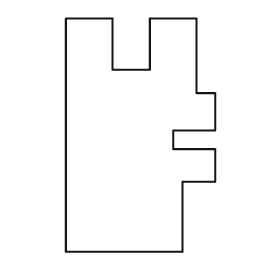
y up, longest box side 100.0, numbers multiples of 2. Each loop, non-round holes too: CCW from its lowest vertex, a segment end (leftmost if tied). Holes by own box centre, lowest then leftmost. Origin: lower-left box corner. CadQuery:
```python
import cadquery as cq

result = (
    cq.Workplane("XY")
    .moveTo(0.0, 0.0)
    .lineTo(50.0, 0.0)
    .lineTo(50.0, 30.0)
    .lineTo(64.0, 30.0)
    .lineTo(64.0, 44.0)
    .lineTo(46.0, 44.0)
    .lineTo(46.0, 52.0)
    .lineTo(64.0, 52.0)
    .lineTo(64.0, 68.0)
    .lineTo(56.0, 68.0)
    .lineTo(56.0, 100.0)
    .lineTo(36.0, 100.0)
    .lineTo(36.0, 78.0)
    .lineTo(20.0, 78.0)
    .lineTo(20.0, 100.0)
    .lineTo(0.0, 100.0)
    .close()
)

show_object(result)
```